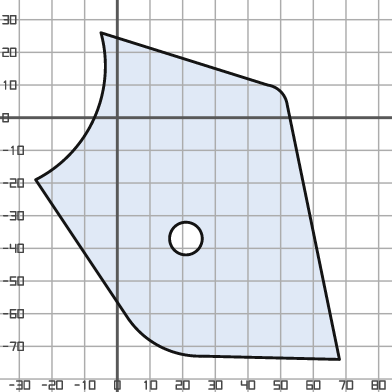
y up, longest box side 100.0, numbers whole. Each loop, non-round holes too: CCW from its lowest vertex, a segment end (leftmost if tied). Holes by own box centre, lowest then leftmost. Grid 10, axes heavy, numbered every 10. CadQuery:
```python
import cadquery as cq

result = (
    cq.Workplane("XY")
    .moveTo(68.0, -74.0)
    .lineTo(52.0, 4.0)
    .threePointArc((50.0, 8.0), (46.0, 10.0))
    .lineTo(-5.0, 26.0)
    .threePointArc((-7.0, 0.0), (-25.0, -19.0))
    .lineTo(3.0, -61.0)
    .threePointArc((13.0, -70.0), (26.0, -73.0))
    .close()
    .moveTo(21.0, -37.0)
    .circle(5.0)
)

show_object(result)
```